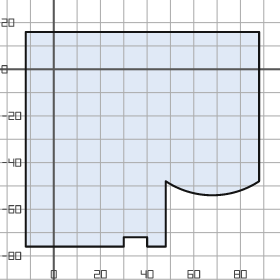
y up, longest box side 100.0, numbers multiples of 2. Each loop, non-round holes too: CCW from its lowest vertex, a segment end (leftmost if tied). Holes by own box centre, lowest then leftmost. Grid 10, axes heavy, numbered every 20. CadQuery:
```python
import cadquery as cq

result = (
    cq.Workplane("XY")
    .moveTo(-12.0, -76.0)
    .lineTo(30.0, -76.0)
    .lineTo(30.0, -72.0)
    .lineTo(40.0, -72.0)
    .lineTo(40.0, -76.0)
    .lineTo(48.0, -76.0)
    .lineTo(48.0, -48.0)
    .threePointArc((68.0, -54.0), (88.0, -48.0))
    .lineTo(88.0, 16.0)
    .lineTo(-12.0, 16.0)
    .close()
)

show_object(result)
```